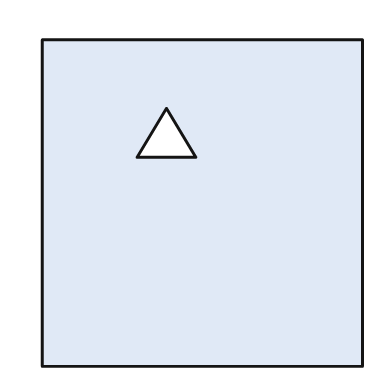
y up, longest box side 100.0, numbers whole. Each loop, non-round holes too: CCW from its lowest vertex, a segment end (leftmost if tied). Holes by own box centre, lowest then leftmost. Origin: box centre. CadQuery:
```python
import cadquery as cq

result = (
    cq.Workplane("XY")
    .moveTo(-49.0, -50.0)
    .lineTo(49.0, -50.0)
    .lineTo(49.0, 50.0)
    .lineTo(-49.0, 50.0)
    .close()
    .moveTo(-20.0, 14.0)
    .lineTo(-2.0, 14.0)
    .lineTo(-11.0, 29.0)
    .close()
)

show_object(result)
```